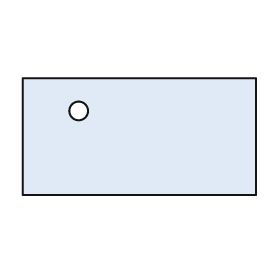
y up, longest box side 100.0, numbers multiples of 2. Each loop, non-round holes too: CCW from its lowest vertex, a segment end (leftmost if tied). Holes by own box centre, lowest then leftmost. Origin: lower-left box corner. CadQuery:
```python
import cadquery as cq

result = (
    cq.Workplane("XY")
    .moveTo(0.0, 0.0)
    .lineTo(100.0, 0.0)
    .lineTo(100.0, 50.0)
    .lineTo(0.0, 50.0)
    .close()
    .moveTo(24.0, 36.0)
    .circle(4.0)
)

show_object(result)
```